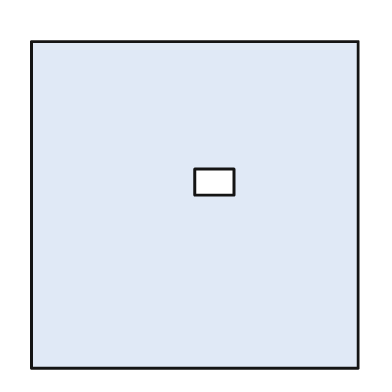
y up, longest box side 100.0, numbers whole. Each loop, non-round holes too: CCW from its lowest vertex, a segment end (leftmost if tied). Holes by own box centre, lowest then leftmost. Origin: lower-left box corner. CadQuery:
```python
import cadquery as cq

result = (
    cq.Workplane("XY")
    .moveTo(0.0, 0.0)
    .lineTo(100.0, 0.0)
    .lineTo(100.0, 100.0)
    .lineTo(0.0, 100.0)
    .close()
    .moveTo(50.0, 53.0)
    .lineTo(62.0, 53.0)
    .lineTo(62.0, 61.0)
    .lineTo(50.0, 61.0)
    .close()
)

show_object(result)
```